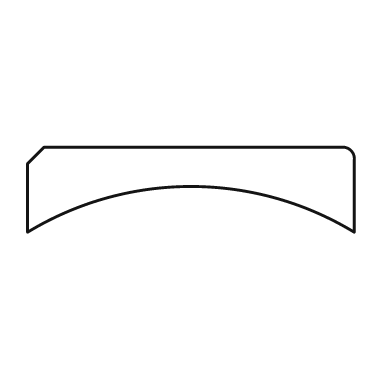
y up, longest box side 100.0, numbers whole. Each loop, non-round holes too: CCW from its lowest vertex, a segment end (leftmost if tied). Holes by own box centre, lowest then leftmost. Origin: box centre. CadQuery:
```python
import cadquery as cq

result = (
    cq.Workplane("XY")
    .moveTo(-50.0, -13.0)
    .threePointArc((0.0, 1.0), (50.0, -13.0))
    .lineTo(50.0, 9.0)
    .threePointArc((49.0, 12.0), (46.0, 13.0))
    .lineTo(-45.0, 13.0)
    .lineTo(-50.0, 8.0)
    .close()
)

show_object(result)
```